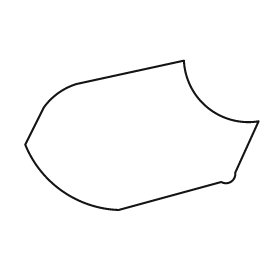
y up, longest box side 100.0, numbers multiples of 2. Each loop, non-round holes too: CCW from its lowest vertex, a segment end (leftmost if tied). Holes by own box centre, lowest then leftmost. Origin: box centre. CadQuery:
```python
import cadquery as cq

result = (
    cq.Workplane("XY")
    .moveTo(-10.0, -32.0)
    .lineTo(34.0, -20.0)
    .threePointArc((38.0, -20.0), (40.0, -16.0))
    .lineTo(50.0, 6.0)
    .threePointArc((28.0, 12.0), (18.0, 32.0))
    .lineTo(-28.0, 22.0)
    .threePointArc((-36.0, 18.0), (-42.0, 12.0))
    .lineTo(-50.0, -4.0)
    .threePointArc((-34.0, -24.0), (-10.0, -32.0))
    .close()
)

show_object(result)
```